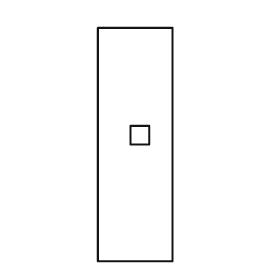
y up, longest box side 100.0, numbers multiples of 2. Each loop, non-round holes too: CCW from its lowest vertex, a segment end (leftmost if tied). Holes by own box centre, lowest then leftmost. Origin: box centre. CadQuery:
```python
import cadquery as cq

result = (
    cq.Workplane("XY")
    .moveTo(-16.0, -50.0)
    .lineTo(16.0, -50.0)
    .lineTo(16.0, 50.0)
    .lineTo(-16.0, 50.0)
    .close()
    .moveTo(-2.0, 0.0)
    .lineTo(6.0, 0.0)
    .lineTo(6.0, 8.0)
    .lineTo(-2.0, 8.0)
    .close()
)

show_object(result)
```